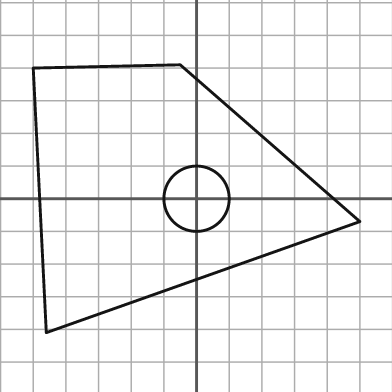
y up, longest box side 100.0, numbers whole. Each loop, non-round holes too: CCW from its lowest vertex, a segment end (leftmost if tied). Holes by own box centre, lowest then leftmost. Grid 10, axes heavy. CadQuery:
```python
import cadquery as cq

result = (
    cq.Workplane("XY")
    .moveTo(-46.0, -41.0)
    .lineTo(50.0, -7.0)
    .lineTo(-5.0, 41.0)
    .lineTo(-50.0, 40.0)
    .close()
    .moveTo(0.0, 0.0)
    .circle(10.0)
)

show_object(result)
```